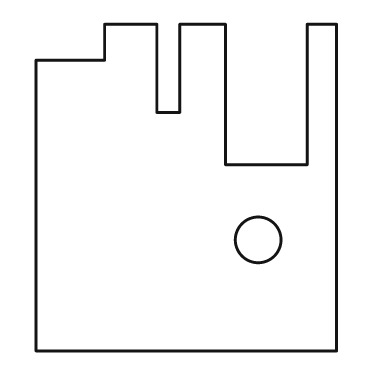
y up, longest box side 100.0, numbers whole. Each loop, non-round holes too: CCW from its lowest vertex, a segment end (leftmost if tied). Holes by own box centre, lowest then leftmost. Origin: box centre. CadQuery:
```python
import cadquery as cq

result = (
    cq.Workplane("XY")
    .moveTo(-46.0, -50.0)
    .lineTo(46.0, -50.0)
    .lineTo(46.0, 50.0)
    .lineTo(37.0, 50.0)
    .lineTo(37.0, 7.0)
    .lineTo(12.0, 7.0)
    .lineTo(12.0, 50.0)
    .lineTo(-2.0, 50.0)
    .lineTo(-2.0, 23.0)
    .lineTo(-9.0, 23.0)
    .lineTo(-9.0, 50.0)
    .lineTo(-25.0, 50.0)
    .lineTo(-25.0, 39.0)
    .lineTo(-46.0, 39.0)
    .close()
    .moveTo(22.0, -16.0)
    .circle(7.0)
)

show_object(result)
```